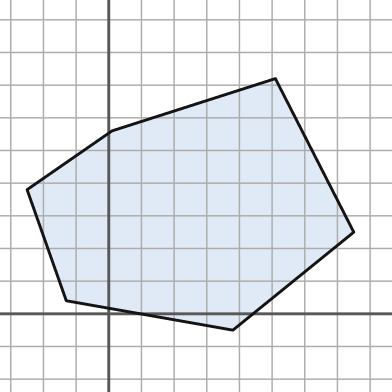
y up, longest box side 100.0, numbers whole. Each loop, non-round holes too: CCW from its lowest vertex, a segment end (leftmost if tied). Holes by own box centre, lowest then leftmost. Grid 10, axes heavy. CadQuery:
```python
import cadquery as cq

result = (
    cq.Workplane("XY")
    .moveTo(38.0, -5.0)
    .lineTo(75.0, 25.0)
    .lineTo(51.0, 72.0)
    .lineTo(1.0, 56.0)
    .lineTo(-25.0, 38.0)
    .lineTo(-13.0, 4.0)
    .close()
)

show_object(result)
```